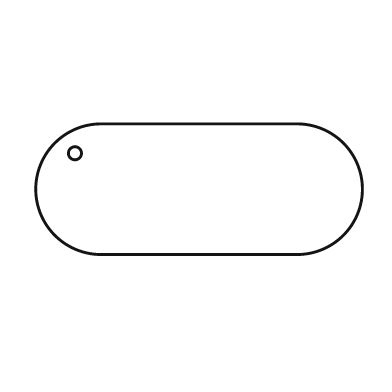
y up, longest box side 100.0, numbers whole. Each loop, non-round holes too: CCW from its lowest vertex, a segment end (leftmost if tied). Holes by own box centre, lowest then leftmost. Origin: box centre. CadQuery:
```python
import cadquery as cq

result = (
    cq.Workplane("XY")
    .moveTo(-30.0, -20.0)
    .lineTo(30.0, -20.0)
    .threePointArc((50.0, 0.0), (30.0, 20.0))
    .lineTo(-30.0, 20.0)
    .threePointArc((-50.0, 0.0), (-30.0, -20.0))
    .close()
    .moveTo(-38.0, 11.0)
    .circle(2.0)
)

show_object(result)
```